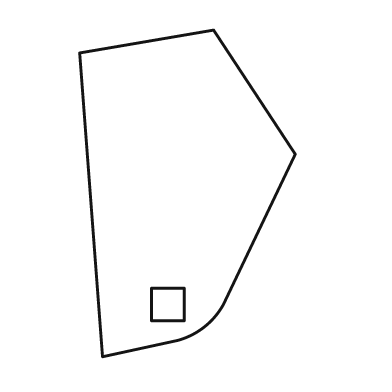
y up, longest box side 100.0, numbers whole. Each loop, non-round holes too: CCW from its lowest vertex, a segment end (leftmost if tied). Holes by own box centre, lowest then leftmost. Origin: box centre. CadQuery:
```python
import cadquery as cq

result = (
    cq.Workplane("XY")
    .moveTo(-26.0, -50.0)
    .lineTo(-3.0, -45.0)
    .threePointArc((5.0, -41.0), (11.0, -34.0))
    .lineTo(33.0, 12.0)
    .lineTo(8.0, 50.0)
    .lineTo(-33.0, 43.0)
    .close()
    .moveTo(-11.0, -39.0)
    .lineTo(-1.0, -39.0)
    .lineTo(-1.0, -29.0)
    .lineTo(-11.0, -29.0)
    .close()
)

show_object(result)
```